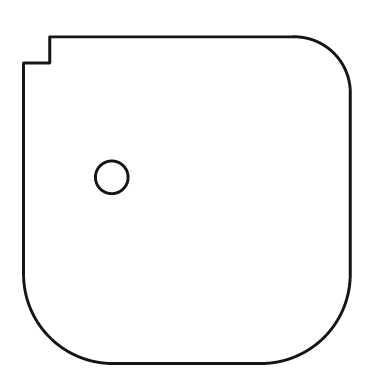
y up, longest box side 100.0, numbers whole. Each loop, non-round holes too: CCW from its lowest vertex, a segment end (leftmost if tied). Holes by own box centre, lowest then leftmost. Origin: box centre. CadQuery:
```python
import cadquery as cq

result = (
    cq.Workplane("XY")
    .moveTo(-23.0, -50.0)
    .lineTo(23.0, -50.0)
    .threePointArc((42.0, -42.0), (50.0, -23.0))
    .lineTo(50.0, 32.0)
    .threePointArc((45.0, 45.0), (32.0, 50.0))
    .lineTo(-42.0, 50.0)
    .lineTo(-42.0, 42.0)
    .lineTo(-50.0, 42.0)
    .lineTo(-50.0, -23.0)
    .threePointArc((-42.0, -42.0), (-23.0, -50.0))
    .close()
    .moveTo(-23.0, 7.0)
    .circle(5.0)
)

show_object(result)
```